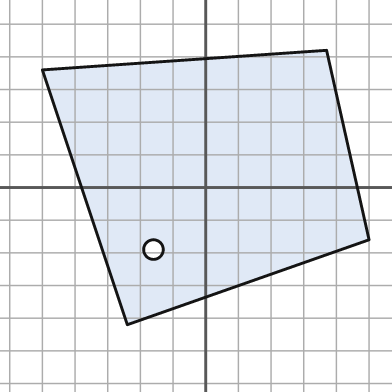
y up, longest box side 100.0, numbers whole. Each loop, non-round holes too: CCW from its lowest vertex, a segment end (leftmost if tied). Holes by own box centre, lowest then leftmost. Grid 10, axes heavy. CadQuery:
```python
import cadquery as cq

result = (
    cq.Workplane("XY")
    .moveTo(-24.0, -42.0)
    .lineTo(50.0, -16.0)
    .lineTo(37.0, 42.0)
    .lineTo(-50.0, 36.0)
    .close()
    .moveTo(-16.0, -19.0)
    .circle(3.0)
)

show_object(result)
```